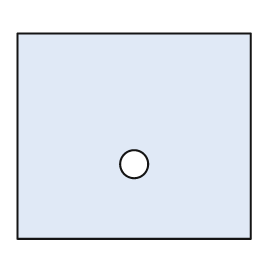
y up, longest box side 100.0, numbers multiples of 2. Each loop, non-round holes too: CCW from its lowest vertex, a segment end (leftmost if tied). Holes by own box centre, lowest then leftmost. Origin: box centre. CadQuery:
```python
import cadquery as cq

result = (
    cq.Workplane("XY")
    .moveTo(-50.0, -44.0)
    .lineTo(50.0, -44.0)
    .lineTo(50.0, 44.0)
    .lineTo(-50.0, 44.0)
    .close()
    .moveTo(0.0, -12.0)
    .circle(6.0)
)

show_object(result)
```